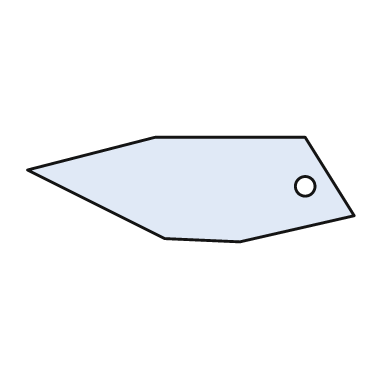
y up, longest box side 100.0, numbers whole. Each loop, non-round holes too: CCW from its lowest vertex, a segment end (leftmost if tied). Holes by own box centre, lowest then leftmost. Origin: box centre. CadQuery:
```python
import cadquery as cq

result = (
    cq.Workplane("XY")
    .moveTo(15.0, -16.0)
    .lineTo(50.0, -8.0)
    .lineTo(35.0, 16.0)
    .lineTo(-11.0, 16.0)
    .lineTo(-50.0, 6.0)
    .lineTo(-8.0, -15.0)
    .close()
    .moveTo(35.0, 1.0)
    .circle(3.0)
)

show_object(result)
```